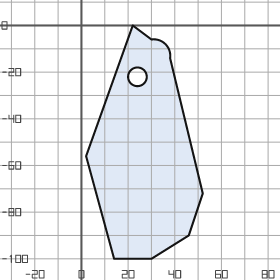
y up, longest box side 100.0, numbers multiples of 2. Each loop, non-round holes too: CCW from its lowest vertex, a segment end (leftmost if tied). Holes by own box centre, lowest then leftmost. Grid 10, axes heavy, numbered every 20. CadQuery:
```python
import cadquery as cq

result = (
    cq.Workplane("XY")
    .moveTo(14.0, -100.0)
    .lineTo(30.0, -100.0)
    .lineTo(46.0, -90.0)
    .lineTo(52.0, -72.0)
    .lineTo(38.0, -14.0)
    .threePointArc((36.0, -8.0), (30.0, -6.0))
    .lineTo(22.0, 0.0)
    .lineTo(2.0, -56.0)
    .close()
    .moveTo(24.0, -22.0)
    .circle(4.0)
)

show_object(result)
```